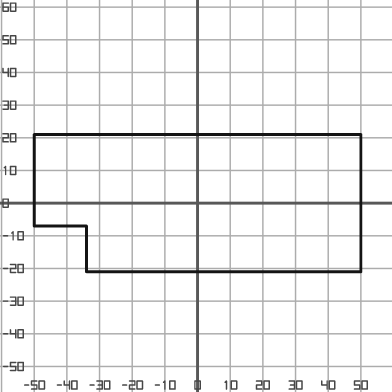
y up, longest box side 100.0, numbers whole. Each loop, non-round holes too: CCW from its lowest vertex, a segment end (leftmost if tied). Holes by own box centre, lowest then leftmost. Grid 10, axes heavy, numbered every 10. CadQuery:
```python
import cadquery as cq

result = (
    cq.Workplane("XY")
    .moveTo(-34.0, -21.0)
    .lineTo(50.0, -21.0)
    .lineTo(50.0, 21.0)
    .lineTo(-50.0, 21.0)
    .lineTo(-50.0, -7.0)
    .lineTo(-34.0, -7.0)
    .close()
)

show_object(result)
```